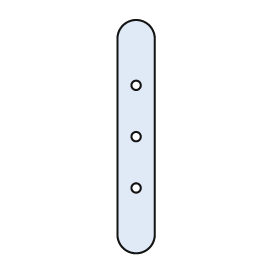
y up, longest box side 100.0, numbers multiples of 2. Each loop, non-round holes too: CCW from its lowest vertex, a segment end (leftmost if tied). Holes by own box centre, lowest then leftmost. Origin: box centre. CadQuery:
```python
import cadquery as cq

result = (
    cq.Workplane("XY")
    .moveTo(-8.0, -42.0)
    .threePointArc((0.0, -50.0), (8.0, -42.0))
    .lineTo(8.0, 42.0)
    .threePointArc((0.0, 50.0), (-8.0, 42.0))
    .close()
    .moveTo(0.0, -22.0)
    .circle(2.0)
    .moveTo(0.0, 0.0)
    .circle(2.0)
    .moveTo(0.0, 22.0)
    .circle(2.0)
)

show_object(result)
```